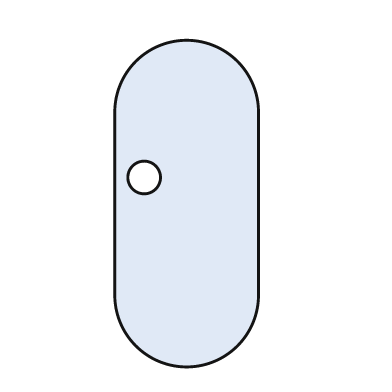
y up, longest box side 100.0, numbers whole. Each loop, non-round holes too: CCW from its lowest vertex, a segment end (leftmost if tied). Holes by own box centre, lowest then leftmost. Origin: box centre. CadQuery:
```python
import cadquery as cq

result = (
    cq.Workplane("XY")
    .moveTo(-22.0, -28.0)
    .threePointArc((0.0, -50.0), (22.0, -28.0))
    .lineTo(22.0, 28.0)
    .threePointArc((0.0, 50.0), (-22.0, 28.0))
    .close()
    .moveTo(-13.0, 8.0)
    .circle(5.0)
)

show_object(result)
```